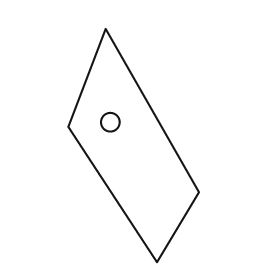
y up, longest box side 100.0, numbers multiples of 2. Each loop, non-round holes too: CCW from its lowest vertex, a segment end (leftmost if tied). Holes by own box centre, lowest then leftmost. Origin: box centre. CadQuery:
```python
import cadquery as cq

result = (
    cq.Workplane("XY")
    .moveTo(10.0, -50.0)
    .lineTo(28.0, -20.0)
    .lineTo(-12.0, 50.0)
    .lineTo(-28.0, 8.0)
    .close()
    .moveTo(-10.0, 10.0)
    .circle(4.0)
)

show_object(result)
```